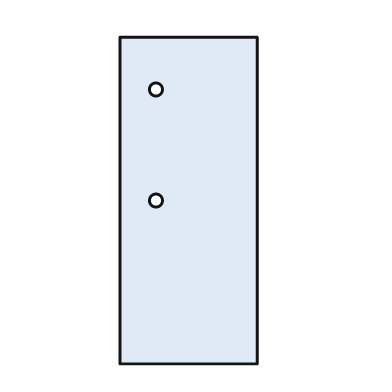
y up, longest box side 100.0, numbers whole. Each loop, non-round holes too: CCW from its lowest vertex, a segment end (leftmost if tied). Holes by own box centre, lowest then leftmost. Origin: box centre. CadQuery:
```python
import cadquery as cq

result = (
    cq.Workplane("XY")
    .moveTo(-21.0, -50.0)
    .lineTo(21.0, -50.0)
    .lineTo(21.0, 50.0)
    .lineTo(-21.0, 50.0)
    .close()
    .moveTo(-10.0, 0.0)
    .circle(2.0)
    .moveTo(-10.0, 34.0)
    .circle(2.0)
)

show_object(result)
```